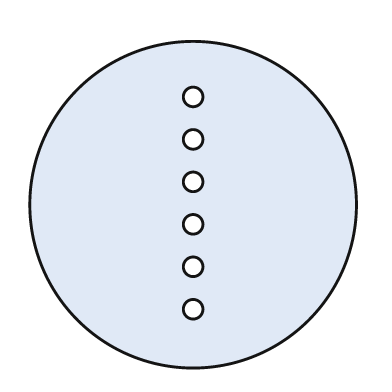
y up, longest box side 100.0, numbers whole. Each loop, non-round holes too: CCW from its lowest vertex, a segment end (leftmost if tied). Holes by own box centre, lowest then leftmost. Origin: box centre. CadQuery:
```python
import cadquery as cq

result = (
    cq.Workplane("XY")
    .moveTo(0.0, 0.0)
    .circle(50.0)
    .moveTo(0.0, -32.0)
    .circle(3.0)
    .moveTo(0.0, -19.0)
    .circle(3.0)
    .moveTo(0.0, -6.0)
    .circle(3.0)
    .moveTo(0.0, 7.0)
    .circle(3.0)
    .moveTo(0.0, 20.0)
    .circle(3.0)
    .moveTo(0.0, 33.0)
    .circle(3.0)
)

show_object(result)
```